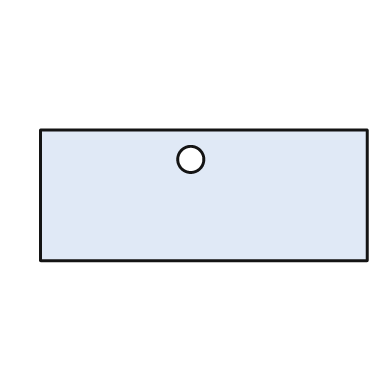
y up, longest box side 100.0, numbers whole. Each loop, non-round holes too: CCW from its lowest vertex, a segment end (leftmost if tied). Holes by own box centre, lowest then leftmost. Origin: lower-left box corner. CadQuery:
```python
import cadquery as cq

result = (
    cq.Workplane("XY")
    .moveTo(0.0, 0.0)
    .lineTo(100.0, 0.0)
    .lineTo(100.0, 40.0)
    .lineTo(0.0, 40.0)
    .close()
    .moveTo(46.0, 31.0)
    .circle(4.0)
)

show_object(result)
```